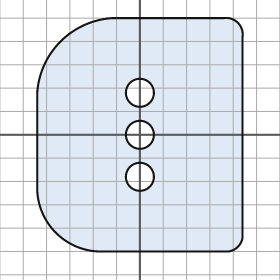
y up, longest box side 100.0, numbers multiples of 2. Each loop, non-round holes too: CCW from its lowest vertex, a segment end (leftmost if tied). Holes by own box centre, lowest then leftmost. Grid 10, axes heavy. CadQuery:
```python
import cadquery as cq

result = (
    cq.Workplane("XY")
    .moveTo(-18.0, -50.0)
    .lineTo(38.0, -50.0)
    .threePointArc((42.0, -48.0), (44.0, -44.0))
    .lineTo(44.0, 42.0)
    .threePointArc((42.0, 48.0), (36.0, 50.0))
    .lineTo(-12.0, 50.0)
    .threePointArc((-34.0, 40.0), (-44.0, 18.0))
    .lineTo(-44.0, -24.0)
    .threePointArc((-36.0, -42.0), (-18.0, -50.0))
    .close()
    .moveTo(0.0, -18.0)
    .circle(6.0)
    .moveTo(0.0, 0.0)
    .circle(6.0)
    .moveTo(0.0, 18.0)
    .circle(6.0)
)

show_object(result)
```